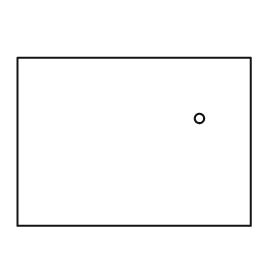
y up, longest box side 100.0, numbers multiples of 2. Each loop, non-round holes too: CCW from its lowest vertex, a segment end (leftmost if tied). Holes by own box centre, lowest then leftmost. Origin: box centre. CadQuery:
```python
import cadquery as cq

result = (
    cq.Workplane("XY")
    .moveTo(-50.0, -36.0)
    .lineTo(50.0, -36.0)
    .lineTo(50.0, 36.0)
    .lineTo(-50.0, 36.0)
    .close()
    .moveTo(28.0, 10.0)
    .circle(2.0)
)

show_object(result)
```